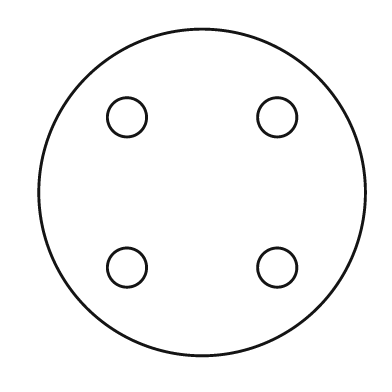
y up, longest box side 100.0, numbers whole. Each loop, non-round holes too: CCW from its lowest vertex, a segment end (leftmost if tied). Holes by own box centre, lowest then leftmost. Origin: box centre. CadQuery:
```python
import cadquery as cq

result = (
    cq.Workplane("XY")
    .moveTo(0.0, 0.0)
    .circle(50.0)
    .moveTo(-23.0, -23.0)
    .circle(6.0)
    .moveTo(23.0, -23.0)
    .circle(6.0)
    .moveTo(-23.0, 23.0)
    .circle(6.0)
    .moveTo(23.0, 23.0)
    .circle(6.0)
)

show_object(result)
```